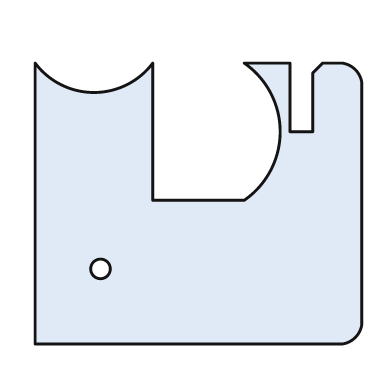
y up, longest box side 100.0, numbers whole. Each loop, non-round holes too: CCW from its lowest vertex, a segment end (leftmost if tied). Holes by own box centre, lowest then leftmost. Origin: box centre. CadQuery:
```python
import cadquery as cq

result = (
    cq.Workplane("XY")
    .moveTo(-50.0, -43.0)
    .lineTo(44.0, -43.0)
    .threePointArc((48.0, -41.0), (50.0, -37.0))
    .lineTo(50.0, 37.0)
    .threePointArc((48.0, 41.0), (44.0, 43.0))
    .lineTo(38.0, 43.0)
    .lineTo(35.0, 40.0)
    .lineTo(35.0, 22.0)
    .lineTo(28.0, 22.0)
    .lineTo(28.0, 43.0)
    .lineTo(14.0, 43.0)
    .threePointArc((25.0, 22.0), (14.0, 1.0))
    .lineTo(-14.0, 1.0)
    .lineTo(-14.0, 43.0)
    .threePointArc((-32.0, 34.0), (-50.0, 43.0))
    .close()
    .moveTo(-30.0, -20.0)
    .circle(3.0)
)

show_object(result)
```